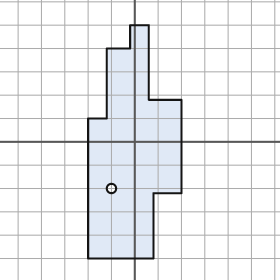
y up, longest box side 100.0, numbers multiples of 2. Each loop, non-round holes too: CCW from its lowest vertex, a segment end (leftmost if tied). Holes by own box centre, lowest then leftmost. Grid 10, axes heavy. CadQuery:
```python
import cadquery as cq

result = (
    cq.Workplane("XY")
    .moveTo(-20.0, -50.0)
    .lineTo(8.0, -50.0)
    .lineTo(8.0, -22.0)
    .lineTo(20.0, -22.0)
    .lineTo(20.0, 18.0)
    .lineTo(6.0, 18.0)
    .lineTo(6.0, 50.0)
    .lineTo(-2.0, 50.0)
    .lineTo(-2.0, 40.0)
    .lineTo(-12.0, 40.0)
    .lineTo(-12.0, 10.0)
    .lineTo(-20.0, 10.0)
    .close()
    .moveTo(-10.0, -20.0)
    .circle(2.0)
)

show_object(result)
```